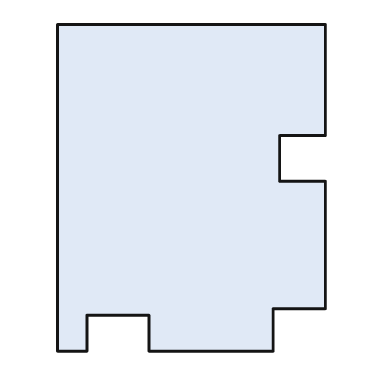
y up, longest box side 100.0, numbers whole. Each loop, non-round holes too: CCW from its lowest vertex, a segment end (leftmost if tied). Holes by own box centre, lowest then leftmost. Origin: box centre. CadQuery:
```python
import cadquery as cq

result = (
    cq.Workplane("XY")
    .moveTo(-41.0, -50.0)
    .lineTo(-32.0, -50.0)
    .lineTo(-32.0, -39.0)
    .lineTo(-13.0, -39.0)
    .lineTo(-13.0, -50.0)
    .lineTo(25.0, -50.0)
    .lineTo(25.0, -37.0)
    .lineTo(41.0, -37.0)
    .lineTo(41.0, 2.0)
    .lineTo(27.0, 2.0)
    .lineTo(27.0, 16.0)
    .lineTo(41.0, 16.0)
    .lineTo(41.0, 50.0)
    .lineTo(-41.0, 50.0)
    .close()
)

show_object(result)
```